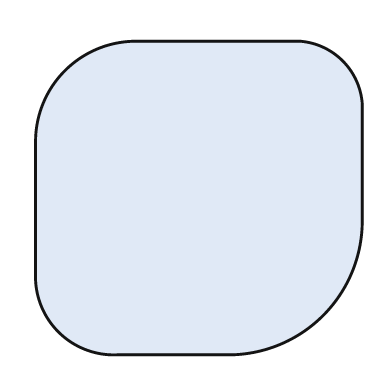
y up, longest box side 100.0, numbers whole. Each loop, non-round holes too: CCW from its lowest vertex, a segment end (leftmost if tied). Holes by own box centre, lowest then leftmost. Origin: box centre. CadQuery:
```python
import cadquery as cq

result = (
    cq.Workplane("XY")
    .moveTo(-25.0, -48.0)
    .lineTo(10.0, -48.0)
    .threePointArc((38.0, -36.0), (50.0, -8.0))
    .lineTo(50.0, 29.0)
    .threePointArc((44.0, 42.0), (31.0, 48.0))
    .lineTo(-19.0, 48.0)
    .threePointArc((-41.0, 39.0), (-50.0, 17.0))
    .lineTo(-50.0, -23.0)
    .threePointArc((-43.0, -41.0), (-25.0, -48.0))
    .close()
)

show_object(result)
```